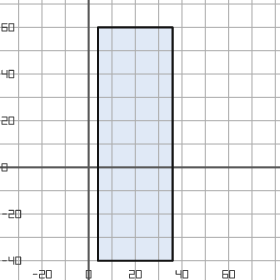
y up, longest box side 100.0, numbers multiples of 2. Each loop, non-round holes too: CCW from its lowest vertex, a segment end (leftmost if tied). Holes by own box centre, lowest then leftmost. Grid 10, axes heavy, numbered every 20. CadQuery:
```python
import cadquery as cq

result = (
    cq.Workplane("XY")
    .moveTo(4.0, -40.0)
    .lineTo(36.0, -40.0)
    .lineTo(36.0, 60.0)
    .lineTo(4.0, 60.0)
    .close()
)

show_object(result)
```